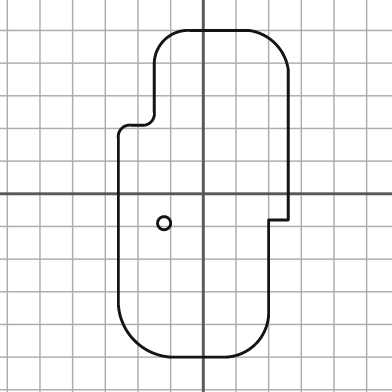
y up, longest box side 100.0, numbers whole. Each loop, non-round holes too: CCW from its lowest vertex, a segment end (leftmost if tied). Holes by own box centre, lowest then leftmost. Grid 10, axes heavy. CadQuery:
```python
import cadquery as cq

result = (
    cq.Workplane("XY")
    .moveTo(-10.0, -50.0)
    .lineTo(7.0, -50.0)
    .threePointArc((16.0, -46.0), (20.0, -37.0))
    .lineTo(20.0, -8.0)
    .lineTo(26.0, -8.0)
    .lineTo(26.0, 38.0)
    .threePointArc((22.0, 46.0), (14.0, 50.0))
    .lineTo(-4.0, 50.0)
    .threePointArc((-12.0, 47.0), (-15.0, 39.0))
    .lineTo(-15.0, 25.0)
    .threePointArc((-16.0, 22.0), (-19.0, 21.0))
    .lineTo(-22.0, 21.0)
    .threePointArc((-25.0, 20.0), (-26.0, 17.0))
    .lineTo(-26.0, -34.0)
    .threePointArc((-21.0, -45.0), (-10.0, -50.0))
    .close()
    .moveTo(-12.0, -9.0)
    .circle(2.0)
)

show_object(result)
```